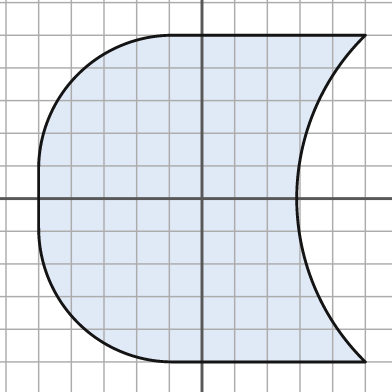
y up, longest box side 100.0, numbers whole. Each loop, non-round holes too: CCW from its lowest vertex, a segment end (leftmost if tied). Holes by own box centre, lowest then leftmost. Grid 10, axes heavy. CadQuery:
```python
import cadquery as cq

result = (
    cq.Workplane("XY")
    .moveTo(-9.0, -50.0)
    .lineTo(50.0, -50.0)
    .threePointArc((29.0, 0.0), (50.0, 50.0))
    .lineTo(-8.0, 50.0)
    .threePointArc((-38.0, 38.0), (-50.0, 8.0))
    .lineTo(-50.0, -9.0)
    .threePointArc((-38.0, -38.0), (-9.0, -50.0))
    .close()
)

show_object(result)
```